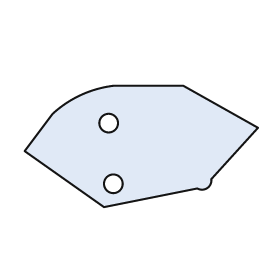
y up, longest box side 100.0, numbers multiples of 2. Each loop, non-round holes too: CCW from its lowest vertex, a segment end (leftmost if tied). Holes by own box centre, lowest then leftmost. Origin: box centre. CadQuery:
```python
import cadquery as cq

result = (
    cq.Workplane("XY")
    .moveTo(-16.0, -26.0)
    .lineTo(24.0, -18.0)
    .threePointArc((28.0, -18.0), (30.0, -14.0))
    .lineTo(50.0, 8.0)
    .lineTo(18.0, 26.0)
    .lineTo(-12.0, 26.0)
    .threePointArc((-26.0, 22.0), (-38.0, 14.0))
    .lineTo(-50.0, -2.0)
    .close()
    .moveTo(-12.0, -16.0)
    .circle(4.0)
    .moveTo(-14.0, 10.0)
    .circle(4.0)
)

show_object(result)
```